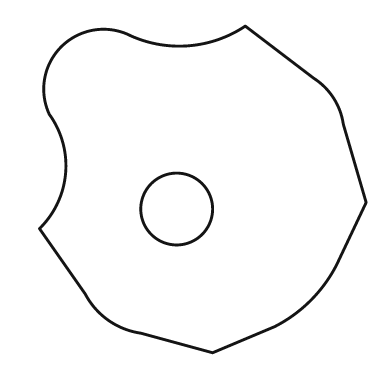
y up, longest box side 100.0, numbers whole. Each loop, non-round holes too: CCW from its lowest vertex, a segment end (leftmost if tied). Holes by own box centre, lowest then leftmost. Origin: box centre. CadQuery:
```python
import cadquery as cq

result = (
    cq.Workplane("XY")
    .moveTo(3.0, -50.0)
    .lineTo(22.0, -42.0)
    .threePointArc((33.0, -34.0), (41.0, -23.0))
    .lineTo(50.0, -4.0)
    .lineTo(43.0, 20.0)
    .threePointArc((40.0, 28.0), (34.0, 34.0))
    .lineTo(13.0, 50.0)
    .threePointArc((-4.0, 44.0), (-22.0, 47.0))
    .threePointArc((-43.0, 44.0), (-47.0, 23.0))
    .threePointArc((-42.0, 5.0), (-50.0, -12.0))
    .lineTo(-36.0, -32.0)
    .threePointArc((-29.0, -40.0), (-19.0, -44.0))
    .close()
    .moveTo(-8.0, -6.0)
    .circle(11.0)
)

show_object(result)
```